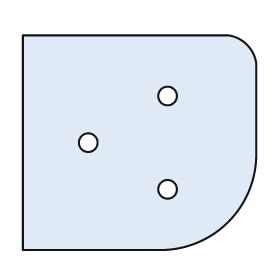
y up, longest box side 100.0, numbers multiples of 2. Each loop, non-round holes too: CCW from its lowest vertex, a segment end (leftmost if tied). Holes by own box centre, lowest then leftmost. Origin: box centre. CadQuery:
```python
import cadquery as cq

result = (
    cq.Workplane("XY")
    .moveTo(-50.0, -46.0)
    .lineTo(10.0, -46.0)
    .threePointArc((38.0, -34.0), (50.0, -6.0))
    .lineTo(50.0, 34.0)
    .threePointArc((46.0, 42.0), (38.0, 46.0))
    .lineTo(-50.0, 46.0)
    .close()
    .moveTo(12.0, -20.0)
    .circle(4.0)
    .moveTo(-22.0, 0.0)
    .circle(4.0)
    .moveTo(12.0, 20.0)
    .circle(4.0)
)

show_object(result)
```